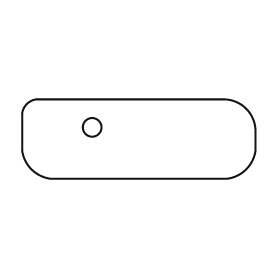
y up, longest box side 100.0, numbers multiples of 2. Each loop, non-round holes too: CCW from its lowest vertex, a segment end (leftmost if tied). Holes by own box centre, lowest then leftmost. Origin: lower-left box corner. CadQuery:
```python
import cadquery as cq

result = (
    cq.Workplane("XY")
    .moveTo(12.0, 0.0)
    .lineTo(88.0, 0.0)
    .threePointArc((96.0, 4.0), (100.0, 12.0))
    .lineTo(100.0, 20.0)
    .threePointArc((96.0, 30.0), (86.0, 34.0))
    .lineTo(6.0, 34.0)
    .threePointArc((2.0, 32.0), (0.0, 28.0))
    .lineTo(0.0, 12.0)
    .threePointArc((4.0, 4.0), (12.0, 0.0))
    .close()
    .moveTo(30.0, 22.0)
    .circle(4.0)
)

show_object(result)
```